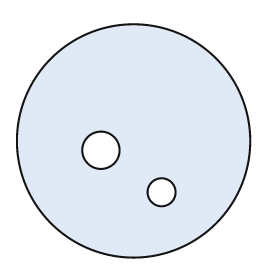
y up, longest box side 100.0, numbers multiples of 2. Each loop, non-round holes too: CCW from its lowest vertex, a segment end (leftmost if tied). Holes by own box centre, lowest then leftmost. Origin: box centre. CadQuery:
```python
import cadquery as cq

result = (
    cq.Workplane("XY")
    .moveTo(0.0, 0.0)
    .circle(50.0)
    .moveTo(12.0, -22.0)
    .circle(6.0)
    .moveTo(-14.0, -4.0)
    .circle(8.0)
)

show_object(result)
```